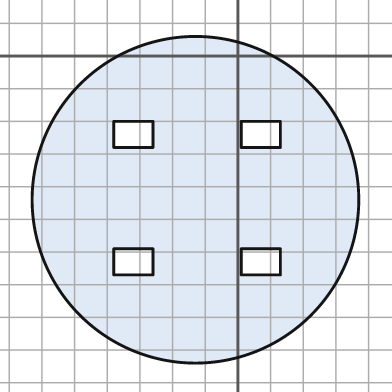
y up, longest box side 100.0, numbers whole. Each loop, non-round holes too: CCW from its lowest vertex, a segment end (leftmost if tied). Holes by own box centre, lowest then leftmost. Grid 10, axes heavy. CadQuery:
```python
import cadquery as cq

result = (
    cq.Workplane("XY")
    .moveTo(-13.0, -44.0)
    .circle(50.0)
    .moveTo(-38.0, -67.0)
    .lineTo(-26.0, -67.0)
    .lineTo(-26.0, -59.0)
    .lineTo(-38.0, -59.0)
    .close()
    .moveTo(1.0, -67.0)
    .lineTo(13.0, -67.0)
    .lineTo(13.0, -59.0)
    .lineTo(1.0, -59.0)
    .close()
    .moveTo(-38.0, -28.0)
    .lineTo(-26.0, -28.0)
    .lineTo(-26.0, -20.0)
    .lineTo(-38.0, -20.0)
    .close()
    .moveTo(1.0, -28.0)
    .lineTo(13.0, -28.0)
    .lineTo(13.0, -20.0)
    .lineTo(1.0, -20.0)
    .close()
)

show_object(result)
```